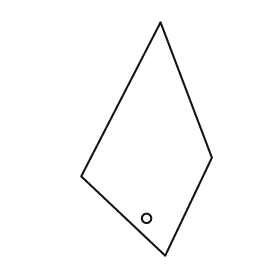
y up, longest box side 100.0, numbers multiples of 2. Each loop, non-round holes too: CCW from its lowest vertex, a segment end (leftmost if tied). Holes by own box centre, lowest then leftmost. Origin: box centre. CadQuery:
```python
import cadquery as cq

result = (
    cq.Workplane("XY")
    .moveTo(8.0, -50.0)
    .lineTo(28.0, -8.0)
    .lineTo(6.0, 50.0)
    .lineTo(-28.0, -16.0)
    .close()
    .moveTo(0.0, -34.0)
    .circle(2.0)
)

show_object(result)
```